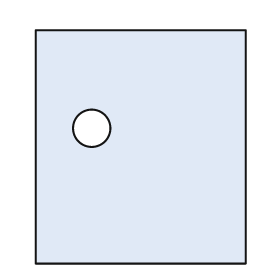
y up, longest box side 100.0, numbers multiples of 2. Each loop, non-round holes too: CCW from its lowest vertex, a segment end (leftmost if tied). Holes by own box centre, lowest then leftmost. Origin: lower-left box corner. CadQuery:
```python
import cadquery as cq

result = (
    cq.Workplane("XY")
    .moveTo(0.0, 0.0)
    .lineTo(90.0, 0.0)
    .lineTo(90.0, 100.0)
    .lineTo(0.0, 100.0)
    .close()
    .moveTo(24.0, 58.0)
    .circle(8.0)
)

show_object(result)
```